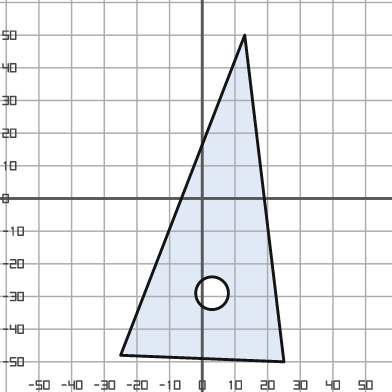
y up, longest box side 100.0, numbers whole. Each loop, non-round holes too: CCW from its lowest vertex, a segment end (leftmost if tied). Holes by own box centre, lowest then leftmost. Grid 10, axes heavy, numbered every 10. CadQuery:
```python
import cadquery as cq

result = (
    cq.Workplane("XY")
    .moveTo(25.0, -50.0)
    .lineTo(13.0, 50.0)
    .lineTo(-25.0, -48.0)
    .close()
    .moveTo(3.0, -29.0)
    .circle(5.0)
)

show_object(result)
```